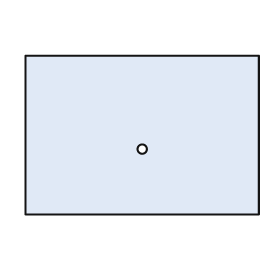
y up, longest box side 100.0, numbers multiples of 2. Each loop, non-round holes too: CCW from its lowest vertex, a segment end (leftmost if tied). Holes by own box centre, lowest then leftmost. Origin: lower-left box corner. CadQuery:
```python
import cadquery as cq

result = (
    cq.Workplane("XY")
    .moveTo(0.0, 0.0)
    .lineTo(100.0, 0.0)
    .lineTo(100.0, 68.0)
    .lineTo(0.0, 68.0)
    .close()
    .moveTo(50.0, 28.0)
    .circle(2.0)
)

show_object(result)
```